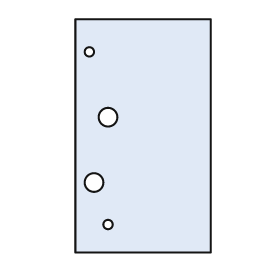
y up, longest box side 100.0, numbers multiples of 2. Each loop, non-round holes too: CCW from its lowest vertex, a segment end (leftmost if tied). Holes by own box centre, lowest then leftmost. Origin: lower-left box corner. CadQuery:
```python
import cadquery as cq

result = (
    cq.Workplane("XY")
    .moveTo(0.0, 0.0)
    .lineTo(58.0, 0.0)
    .lineTo(58.0, 100.0)
    .lineTo(0.0, 100.0)
    .close()
    .moveTo(14.0, 12.0)
    .circle(2.0)
    .moveTo(8.0, 30.0)
    .circle(4.0)
    .moveTo(14.0, 58.0)
    .circle(4.0)
    .moveTo(6.0, 86.0)
    .circle(2.0)
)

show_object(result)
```